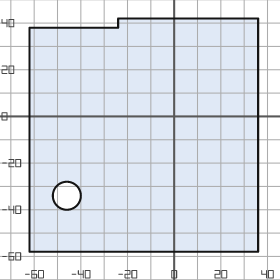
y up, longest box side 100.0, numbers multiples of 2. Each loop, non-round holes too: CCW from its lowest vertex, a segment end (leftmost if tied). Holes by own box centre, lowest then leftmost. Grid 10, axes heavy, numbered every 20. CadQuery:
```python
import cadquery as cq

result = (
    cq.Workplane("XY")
    .moveTo(-62.0, -58.0)
    .lineTo(36.0, -58.0)
    .lineTo(36.0, 42.0)
    .lineTo(-24.0, 42.0)
    .lineTo(-24.0, 38.0)
    .lineTo(-62.0, 38.0)
    .close()
    .moveTo(-46.0, -34.0)
    .circle(6.0)
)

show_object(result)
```